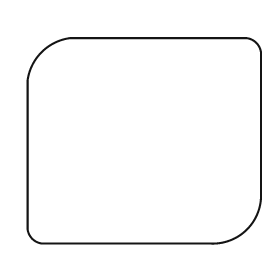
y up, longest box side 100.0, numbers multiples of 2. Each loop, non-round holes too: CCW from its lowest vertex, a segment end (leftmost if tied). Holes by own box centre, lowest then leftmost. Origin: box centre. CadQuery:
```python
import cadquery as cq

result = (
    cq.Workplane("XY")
    .moveTo(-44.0, -44.0)
    .lineTo(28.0, -44.0)
    .threePointArc((44.0, -38.0), (50.0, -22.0))
    .lineTo(50.0, 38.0)
    .threePointArc((48.0, 42.0), (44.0, 44.0))
    .lineTo(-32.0, 44.0)
    .threePointArc((-44.0, 38.0), (-50.0, 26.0))
    .lineTo(-50.0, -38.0)
    .threePointArc((-48.0, -42.0), (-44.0, -44.0))
    .close()
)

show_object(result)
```